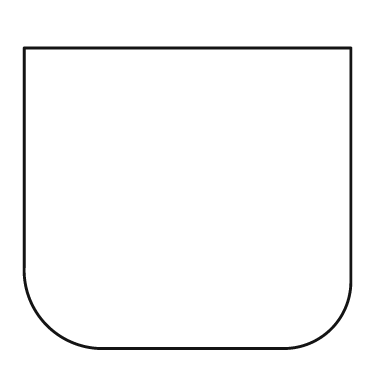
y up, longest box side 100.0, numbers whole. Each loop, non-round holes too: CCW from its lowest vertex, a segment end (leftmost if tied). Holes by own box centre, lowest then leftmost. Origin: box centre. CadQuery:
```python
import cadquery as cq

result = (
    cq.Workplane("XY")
    .moveTo(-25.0, -46.0)
    .lineTo(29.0, -46.0)
    .threePointArc((44.0, -40.0), (50.0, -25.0))
    .lineTo(50.0, 46.0)
    .lineTo(-50.0, 46.0)
    .lineTo(-50.0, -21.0)
    .threePointArc((-43.0, -39.0), (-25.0, -46.0))
    .close()
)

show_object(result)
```